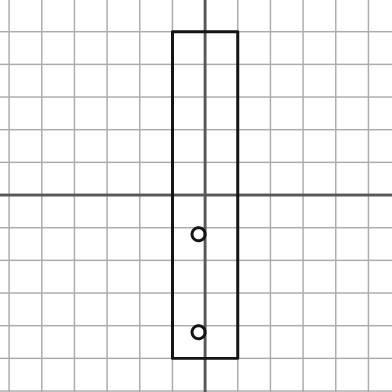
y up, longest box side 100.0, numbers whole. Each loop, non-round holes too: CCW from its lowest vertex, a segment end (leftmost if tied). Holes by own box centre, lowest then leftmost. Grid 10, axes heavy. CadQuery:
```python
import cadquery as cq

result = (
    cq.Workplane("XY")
    .moveTo(-10.0, -50.0)
    .lineTo(10.0, -50.0)
    .lineTo(10.0, 50.0)
    .lineTo(-10.0, 50.0)
    .close()
    .moveTo(-2.0, -42.0)
    .circle(2.0)
    .moveTo(-2.0, -12.0)
    .circle(2.0)
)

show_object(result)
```